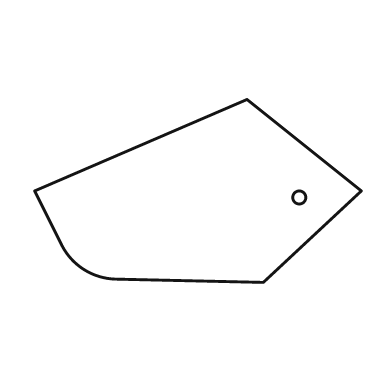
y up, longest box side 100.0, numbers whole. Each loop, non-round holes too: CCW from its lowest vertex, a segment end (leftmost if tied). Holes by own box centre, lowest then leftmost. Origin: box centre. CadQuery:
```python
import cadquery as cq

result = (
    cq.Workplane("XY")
    .moveTo(20.0, -28.0)
    .lineTo(50.0, 0.0)
    .lineTo(15.0, 28.0)
    .lineTo(-50.0, 0.0)
    .lineTo(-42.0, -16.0)
    .threePointArc((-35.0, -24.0), (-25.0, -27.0))
    .close()
    .moveTo(31.0, -2.0)
    .circle(2.0)
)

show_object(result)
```